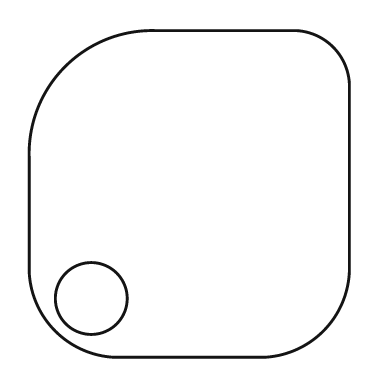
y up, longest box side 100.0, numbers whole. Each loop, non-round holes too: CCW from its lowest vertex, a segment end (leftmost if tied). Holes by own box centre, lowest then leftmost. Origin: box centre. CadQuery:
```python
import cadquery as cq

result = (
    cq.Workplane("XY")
    .moveTo(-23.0, -50.0)
    .lineTo(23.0, -50.0)
    .threePointArc((41.0, -42.0), (49.0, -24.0))
    .lineTo(49.0, 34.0)
    .threePointArc((44.0, 45.0), (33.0, 50.0))
    .lineTo(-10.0, 50.0)
    .threePointArc((-38.0, 39.0), (-49.0, 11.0))
    .lineTo(-49.0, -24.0)
    .threePointArc((-41.0, -42.0), (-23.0, -50.0))
    .close()
    .moveTo(-30.0, -32.0)
    .circle(11.0)
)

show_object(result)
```